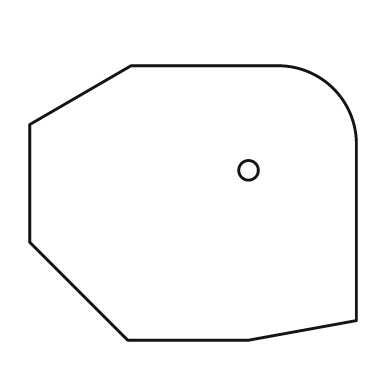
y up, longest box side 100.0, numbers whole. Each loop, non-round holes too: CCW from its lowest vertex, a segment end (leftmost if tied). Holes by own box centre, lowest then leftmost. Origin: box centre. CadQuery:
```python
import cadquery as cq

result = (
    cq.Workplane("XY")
    .moveTo(-20.0, -42.0)
    .lineTo(17.0, -42.0)
    .lineTo(50.0, -36.0)
    .lineTo(50.0, 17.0)
    .threePointArc((43.0, 35.0), (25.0, 42.0))
    .lineTo(-19.0, 42.0)
    .lineTo(-50.0, 24.0)
    .lineTo(-50.0, -12.0)
    .close()
    .moveTo(17.0, 10.0)
    .circle(3.0)
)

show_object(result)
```